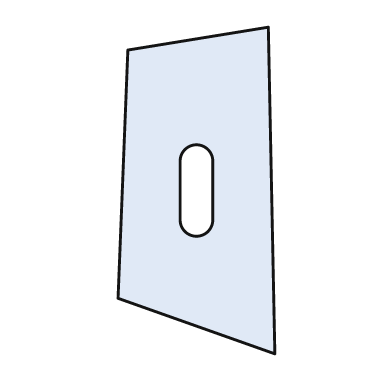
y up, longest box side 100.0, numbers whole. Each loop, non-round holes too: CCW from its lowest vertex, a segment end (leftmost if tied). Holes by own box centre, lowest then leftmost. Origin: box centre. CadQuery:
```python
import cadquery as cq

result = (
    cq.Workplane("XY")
    .moveTo(24.0, -50.0)
    .lineTo(22.0, 50.0)
    .lineTo(-21.0, 43.0)
    .lineTo(-24.0, -33.0)
    .close()
    .moveTo(-5.0, -9.0)
    .threePointArc((0.0, -14.0), (5.0, -9.0))
    .lineTo(5.0, 9.0)
    .threePointArc((0.0, 14.0), (-5.0, 9.0))
    .close()
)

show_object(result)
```